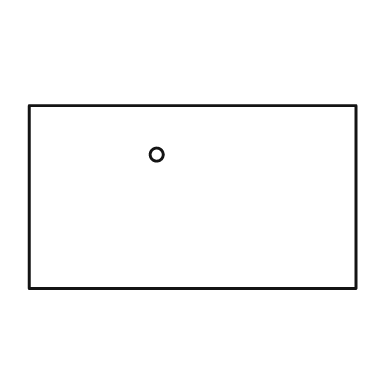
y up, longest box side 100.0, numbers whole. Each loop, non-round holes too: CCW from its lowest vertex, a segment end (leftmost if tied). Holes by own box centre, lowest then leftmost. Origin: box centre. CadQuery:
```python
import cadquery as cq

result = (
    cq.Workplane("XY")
    .moveTo(-50.0, -28.0)
    .lineTo(50.0, -28.0)
    .lineTo(50.0, 28.0)
    .lineTo(-50.0, 28.0)
    .close()
    .moveTo(-11.0, 13.0)
    .circle(2.0)
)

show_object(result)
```